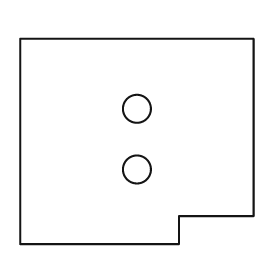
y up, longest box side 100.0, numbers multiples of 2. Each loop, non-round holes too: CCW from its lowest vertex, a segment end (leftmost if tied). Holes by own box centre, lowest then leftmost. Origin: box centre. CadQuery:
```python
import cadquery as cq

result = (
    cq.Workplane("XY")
    .moveTo(-50.0, -44.0)
    .lineTo(18.0, -44.0)
    .lineTo(18.0, -32.0)
    .lineTo(50.0, -32.0)
    .lineTo(50.0, 44.0)
    .lineTo(-50.0, 44.0)
    .close()
    .moveTo(0.0, -12.0)
    .circle(6.0)
    .moveTo(0.0, 14.0)
    .circle(6.0)
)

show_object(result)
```